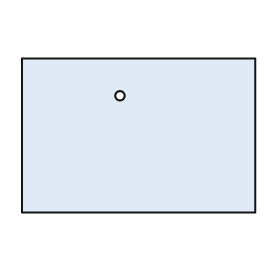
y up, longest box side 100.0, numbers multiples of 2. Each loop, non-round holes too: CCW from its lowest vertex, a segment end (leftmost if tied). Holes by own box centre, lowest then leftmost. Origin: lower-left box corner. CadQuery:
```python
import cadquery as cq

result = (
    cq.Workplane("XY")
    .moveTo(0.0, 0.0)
    .lineTo(100.0, 0.0)
    .lineTo(100.0, 66.0)
    .lineTo(0.0, 66.0)
    .close()
    .moveTo(42.0, 50.0)
    .circle(2.0)
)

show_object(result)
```